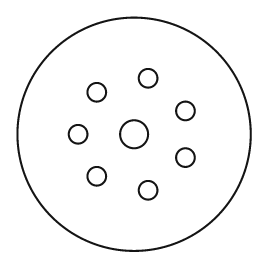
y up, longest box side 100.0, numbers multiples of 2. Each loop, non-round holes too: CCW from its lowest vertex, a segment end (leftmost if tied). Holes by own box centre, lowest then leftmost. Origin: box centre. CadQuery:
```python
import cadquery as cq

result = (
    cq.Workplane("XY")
    .moveTo(0.0, 0.0)
    .circle(50.0)
    .moveTo(6.0, -24.0)
    .circle(4.0)
    .moveTo(-16.0, -18.0)
    .circle(4.0)
    .moveTo(22.0, -10.0)
    .circle(4.0)
    .moveTo(-24.0, 0.0)
    .circle(4.0)
    .moveTo(0.0, 0.0)
    .circle(6.0)
    .moveTo(22.0, 10.0)
    .circle(4.0)
    .moveTo(-16.0, 18.0)
    .circle(4.0)
    .moveTo(6.0, 24.0)
    .circle(4.0)
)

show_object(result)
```